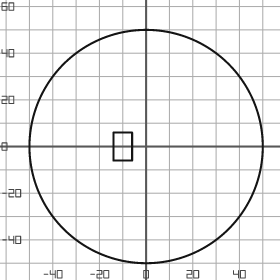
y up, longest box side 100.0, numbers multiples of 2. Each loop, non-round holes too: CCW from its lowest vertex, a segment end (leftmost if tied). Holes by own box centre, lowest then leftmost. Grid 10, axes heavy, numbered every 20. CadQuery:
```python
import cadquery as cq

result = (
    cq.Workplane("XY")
    .moveTo(0.0, 0.0)
    .circle(50.0)
    .moveTo(-14.0, -6.0)
    .lineTo(-6.0, -6.0)
    .lineTo(-6.0, 6.0)
    .lineTo(-14.0, 6.0)
    .close()
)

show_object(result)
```